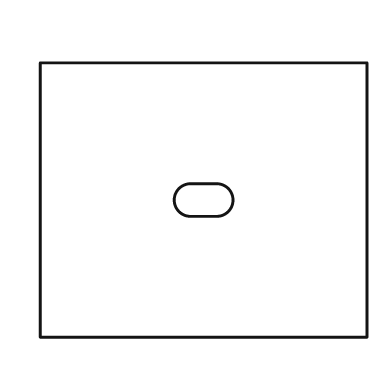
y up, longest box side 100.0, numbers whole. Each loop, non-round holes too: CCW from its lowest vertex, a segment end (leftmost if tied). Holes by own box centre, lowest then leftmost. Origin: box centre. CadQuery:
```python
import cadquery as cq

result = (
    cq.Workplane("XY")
    .moveTo(-50.0, -42.0)
    .lineTo(50.0, -42.0)
    .lineTo(50.0, 42.0)
    .lineTo(-50.0, 42.0)
    .close()
    .moveTo(-4.0, -5.0)
    .lineTo(4.0, -5.0)
    .threePointArc((9.0, 0.0), (4.0, 5.0))
    .lineTo(-4.0, 5.0)
    .threePointArc((-9.0, 0.0), (-4.0, -5.0))
    .close()
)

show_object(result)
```